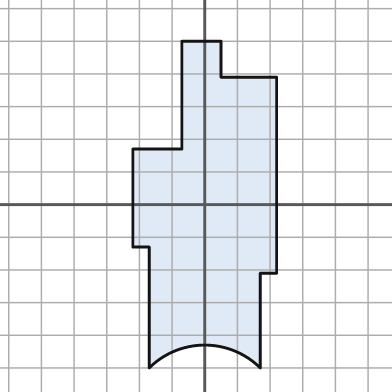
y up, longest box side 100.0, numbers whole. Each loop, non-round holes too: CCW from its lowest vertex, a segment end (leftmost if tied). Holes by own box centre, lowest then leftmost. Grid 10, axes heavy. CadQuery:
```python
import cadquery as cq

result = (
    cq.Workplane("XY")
    .moveTo(-17.0, -50.0)
    .threePointArc((0.0, -43.0), (17.0, -50.0))
    .lineTo(17.0, -21.0)
    .lineTo(22.0, -21.0)
    .lineTo(22.0, 39.0)
    .lineTo(5.0, 39.0)
    .lineTo(5.0, 50.0)
    .lineTo(-7.0, 50.0)
    .lineTo(-7.0, 17.0)
    .lineTo(-22.0, 17.0)
    .lineTo(-22.0, -13.0)
    .lineTo(-17.0, -13.0)
    .close()
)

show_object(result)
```